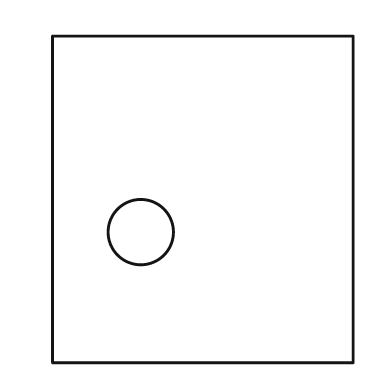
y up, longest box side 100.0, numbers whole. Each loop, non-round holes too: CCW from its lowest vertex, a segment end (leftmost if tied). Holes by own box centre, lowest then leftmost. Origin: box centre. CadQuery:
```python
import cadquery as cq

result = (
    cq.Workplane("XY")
    .moveTo(-46.0, -50.0)
    .lineTo(46.0, -50.0)
    .lineTo(46.0, 50.0)
    .lineTo(-46.0, 50.0)
    .close()
    .moveTo(-19.0, -10.0)
    .circle(10.0)
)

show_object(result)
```